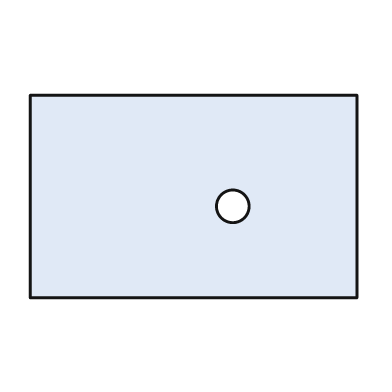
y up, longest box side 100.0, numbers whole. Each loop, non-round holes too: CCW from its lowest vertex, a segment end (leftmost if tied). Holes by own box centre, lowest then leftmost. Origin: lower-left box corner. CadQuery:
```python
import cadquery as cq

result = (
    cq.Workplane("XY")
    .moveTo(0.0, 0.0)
    .lineTo(100.0, 0.0)
    .lineTo(100.0, 62.0)
    .lineTo(0.0, 62.0)
    .close()
    .moveTo(62.0, 28.0)
    .circle(5.0)
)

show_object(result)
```